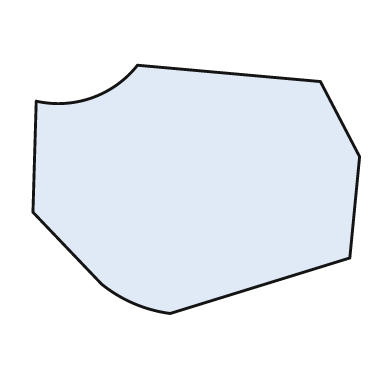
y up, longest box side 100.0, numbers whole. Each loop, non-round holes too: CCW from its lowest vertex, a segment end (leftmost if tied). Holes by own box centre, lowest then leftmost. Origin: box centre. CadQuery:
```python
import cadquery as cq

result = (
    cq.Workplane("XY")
    .moveTo(-8.0, -38.0)
    .lineTo(47.0, -21.0)
    .lineTo(50.0, 10.0)
    .lineTo(38.0, 33.0)
    .lineTo(-18.0, 38.0)
    .threePointArc((-32.0, 28.0), (-49.0, 27.0))
    .lineTo(-50.0, -7.0)
    .lineTo(-29.0, -29.0)
    .threePointArc((-19.0, -35.0), (-8.0, -38.0))
    .close()
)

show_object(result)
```